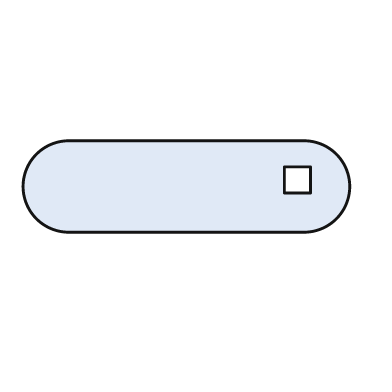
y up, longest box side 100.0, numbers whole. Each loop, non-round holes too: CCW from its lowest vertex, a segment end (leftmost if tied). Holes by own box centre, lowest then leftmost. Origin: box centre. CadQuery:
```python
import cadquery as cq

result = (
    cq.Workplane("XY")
    .moveTo(-36.0, -14.0)
    .lineTo(36.0, -14.0)
    .threePointArc((50.0, 0.0), (36.0, 14.0))
    .lineTo(-36.0, 14.0)
    .threePointArc((-50.0, 0.0), (-36.0, -14.0))
    .close()
    .moveTo(30.0, -2.0)
    .lineTo(38.0, -2.0)
    .lineTo(38.0, 6.0)
    .lineTo(30.0, 6.0)
    .close()
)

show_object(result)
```